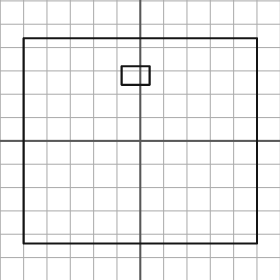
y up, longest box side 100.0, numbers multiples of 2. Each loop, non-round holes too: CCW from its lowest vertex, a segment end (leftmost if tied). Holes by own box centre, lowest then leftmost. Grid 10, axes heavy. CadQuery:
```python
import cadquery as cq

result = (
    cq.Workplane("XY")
    .moveTo(-50.0, -44.0)
    .lineTo(50.0, -44.0)
    .lineTo(50.0, 44.0)
    .lineTo(-50.0, 44.0)
    .close()
    .moveTo(-8.0, 24.0)
    .lineTo(4.0, 24.0)
    .lineTo(4.0, 32.0)
    .lineTo(-8.0, 32.0)
    .close()
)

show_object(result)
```